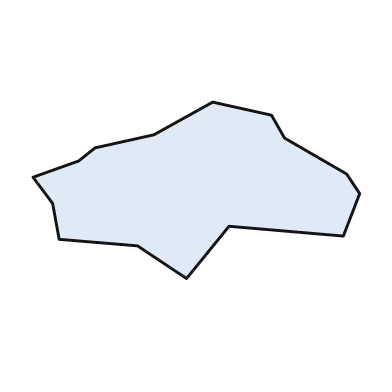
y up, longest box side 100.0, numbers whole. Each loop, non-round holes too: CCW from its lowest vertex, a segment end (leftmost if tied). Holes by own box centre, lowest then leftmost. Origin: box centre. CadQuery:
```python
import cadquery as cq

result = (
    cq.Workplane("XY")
    .moveTo(-3.0, -27.0)
    .lineTo(10.0, -11.0)
    .lineTo(45.0, -14.0)
    .lineTo(50.0, -1.0)
    .lineTo(46.0, 5.0)
    .lineTo(27.0, 16.0)
    .lineTo(23.0, 23.0)
    .lineTo(5.0, 27.0)
    .lineTo(-13.0, 17.0)
    .lineTo(-31.0, 13.0)
    .lineTo(-36.0, 9.0)
    .lineTo(-50.0, 4.0)
    .lineTo(-44.0, -4.0)
    .lineTo(-42.0, -15.0)
    .lineTo(-18.0, -17.0)
    .close()
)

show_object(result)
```